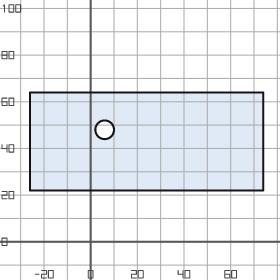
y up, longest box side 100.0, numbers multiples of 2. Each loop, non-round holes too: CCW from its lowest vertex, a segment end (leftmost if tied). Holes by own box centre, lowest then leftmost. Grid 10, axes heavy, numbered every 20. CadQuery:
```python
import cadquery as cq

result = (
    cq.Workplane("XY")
    .moveTo(-26.0, 22.0)
    .lineTo(74.0, 22.0)
    .lineTo(74.0, 64.0)
    .lineTo(-26.0, 64.0)
    .close()
    .moveTo(6.0, 48.0)
    .circle(4.0)
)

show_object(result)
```